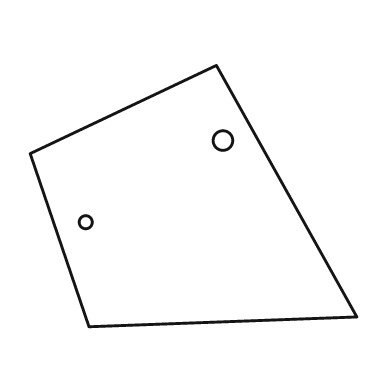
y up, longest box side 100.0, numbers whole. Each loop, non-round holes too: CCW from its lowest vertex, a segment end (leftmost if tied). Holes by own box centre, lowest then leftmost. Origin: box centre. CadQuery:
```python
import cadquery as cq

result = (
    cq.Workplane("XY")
    .moveTo(-32.0, -40.0)
    .lineTo(50.0, -37.0)
    .lineTo(7.0, 40.0)
    .lineTo(-50.0, 13.0)
    .close()
    .moveTo(-33.0, -8.0)
    .circle(2.0)
    .moveTo(9.0, 17.0)
    .circle(3.0)
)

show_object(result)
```